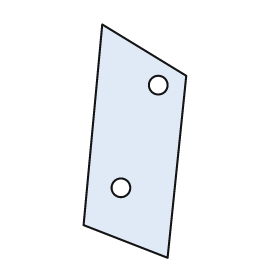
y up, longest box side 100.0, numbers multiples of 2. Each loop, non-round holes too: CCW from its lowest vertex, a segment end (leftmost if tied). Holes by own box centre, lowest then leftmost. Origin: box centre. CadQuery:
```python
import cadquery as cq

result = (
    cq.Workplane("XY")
    .moveTo(14.0, -50.0)
    .lineTo(22.0, 28.0)
    .lineTo(-14.0, 50.0)
    .lineTo(-22.0, -36.0)
    .close()
    .moveTo(-6.0, -20.0)
    .circle(4.0)
    .moveTo(10.0, 24.0)
    .circle(4.0)
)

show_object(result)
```